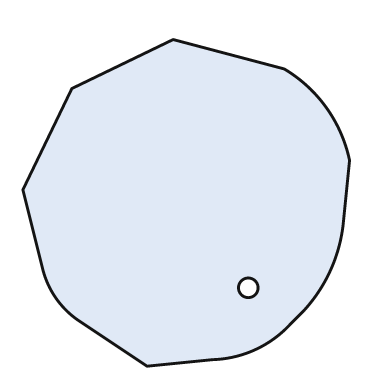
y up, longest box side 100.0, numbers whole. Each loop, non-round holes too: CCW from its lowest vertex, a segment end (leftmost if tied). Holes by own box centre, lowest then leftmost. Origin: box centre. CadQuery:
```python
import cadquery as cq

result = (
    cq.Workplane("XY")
    .moveTo(-12.0, -50.0)
    .lineTo(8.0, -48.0)
    .threePointArc((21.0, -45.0), (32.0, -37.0))
    .lineTo(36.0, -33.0)
    .threePointArc((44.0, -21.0), (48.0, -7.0))
    .lineTo(50.0, 13.0)
    .threePointArc((43.0, 29.0), (30.0, 41.0))
    .lineTo(-4.0, 50.0)
    .lineTo(-35.0, 35.0)
    .lineTo(-50.0, 4.0)
    .lineTo(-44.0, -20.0)
    .threePointArc((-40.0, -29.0), (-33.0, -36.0))
    .close()
    .moveTo(19.0, -26.0)
    .circle(3.0)
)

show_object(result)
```